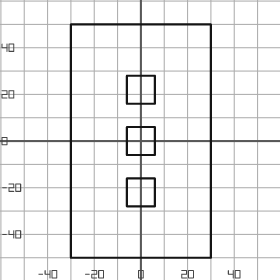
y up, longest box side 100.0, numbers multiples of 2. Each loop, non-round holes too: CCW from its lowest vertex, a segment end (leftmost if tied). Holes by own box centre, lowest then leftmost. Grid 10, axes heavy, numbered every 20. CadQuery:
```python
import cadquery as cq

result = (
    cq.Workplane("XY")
    .moveTo(-30.0, -50.0)
    .lineTo(30.0, -50.0)
    .lineTo(30.0, 50.0)
    .lineTo(-30.0, 50.0)
    .close()
    .moveTo(-6.0, -28.0)
    .lineTo(6.0, -28.0)
    .lineTo(6.0, -16.0)
    .lineTo(-6.0, -16.0)
    .close()
    .moveTo(-6.0, -6.0)
    .lineTo(6.0, -6.0)
    .lineTo(6.0, 6.0)
    .lineTo(-6.0, 6.0)
    .close()
    .moveTo(-6.0, 16.0)
    .lineTo(6.0, 16.0)
    .lineTo(6.0, 28.0)
    .lineTo(-6.0, 28.0)
    .close()
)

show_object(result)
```